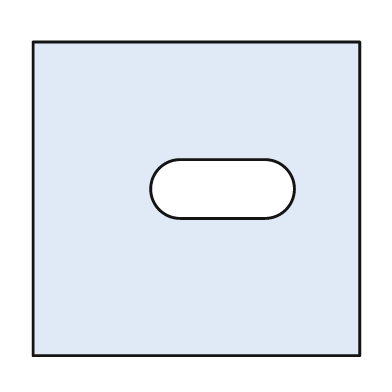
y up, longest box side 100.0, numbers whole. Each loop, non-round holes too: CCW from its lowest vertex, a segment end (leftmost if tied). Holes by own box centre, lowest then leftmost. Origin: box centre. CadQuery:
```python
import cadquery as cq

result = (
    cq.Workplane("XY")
    .moveTo(-50.0, -48.0)
    .lineTo(50.0, -48.0)
    .lineTo(50.0, 48.0)
    .lineTo(-50.0, 48.0)
    .close()
    .moveTo(-5.0, -6.0)
    .lineTo(21.0, -6.0)
    .threePointArc((30.0, 3.0), (21.0, 12.0))
    .lineTo(-5.0, 12.0)
    .threePointArc((-14.0, 3.0), (-5.0, -6.0))
    .close()
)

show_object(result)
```